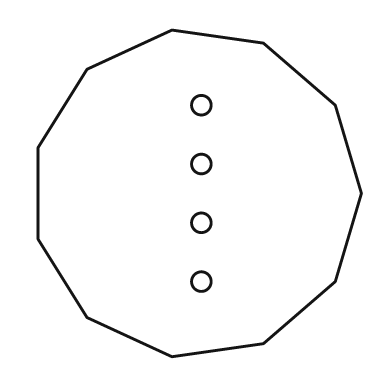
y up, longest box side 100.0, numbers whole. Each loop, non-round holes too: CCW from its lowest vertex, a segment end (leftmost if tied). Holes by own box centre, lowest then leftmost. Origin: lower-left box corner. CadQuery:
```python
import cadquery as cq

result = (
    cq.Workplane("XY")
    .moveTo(41.0, 0.0)
    .lineTo(69.0, 4.0)
    .lineTo(91.0, 23.0)
    .lineTo(99.0, 50.0)
    .lineTo(91.0, 77.0)
    .lineTo(69.0, 96.0)
    .lineTo(41.0, 100.0)
    .lineTo(15.0, 88.0)
    .lineTo(0.0, 64.0)
    .lineTo(0.0, 36.0)
    .lineTo(15.0, 12.0)
    .close()
    .moveTo(50.0, 23.0)
    .circle(3.0)
    .moveTo(50.0, 41.0)
    .circle(3.0)
    .moveTo(50.0, 59.0)
    .circle(3.0)
    .moveTo(50.0, 77.0)
    .circle(3.0)
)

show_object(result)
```